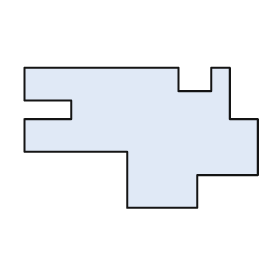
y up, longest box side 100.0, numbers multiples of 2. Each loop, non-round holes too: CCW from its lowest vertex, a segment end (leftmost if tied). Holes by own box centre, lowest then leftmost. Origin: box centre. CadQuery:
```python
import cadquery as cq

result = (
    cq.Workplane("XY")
    .moveTo(-6.0, -30.0)
    .lineTo(24.0, -30.0)
    .lineTo(24.0, -16.0)
    .lineTo(50.0, -16.0)
    .lineTo(50.0, 8.0)
    .lineTo(38.0, 8.0)
    .lineTo(38.0, 30.0)
    .lineTo(30.0, 30.0)
    .lineTo(30.0, 20.0)
    .lineTo(16.0, 20.0)
    .lineTo(16.0, 30.0)
    .lineTo(-50.0, 30.0)
    .lineTo(-50.0, 16.0)
    .lineTo(-30.0, 16.0)
    .lineTo(-30.0, 8.0)
    .lineTo(-50.0, 8.0)
    .lineTo(-50.0, -6.0)
    .lineTo(-6.0, -6.0)
    .close()
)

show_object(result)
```